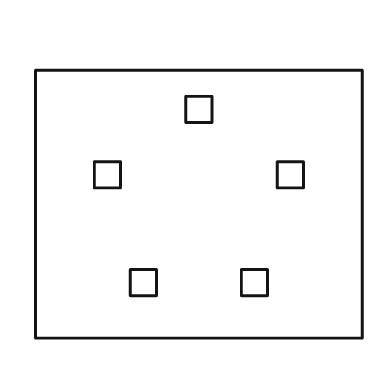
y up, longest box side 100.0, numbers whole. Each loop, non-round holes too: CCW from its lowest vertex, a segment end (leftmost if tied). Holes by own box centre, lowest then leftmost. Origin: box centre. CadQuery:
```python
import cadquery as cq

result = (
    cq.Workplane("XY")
    .moveTo(-50.0, -41.0)
    .lineTo(50.0, -41.0)
    .lineTo(50.0, 41.0)
    .lineTo(-50.0, 41.0)
    .close()
    .moveTo(-21.0, -28.0)
    .lineTo(-13.0, -28.0)
    .lineTo(-13.0, -20.0)
    .lineTo(-21.0, -20.0)
    .close()
    .moveTo(13.0, -28.0)
    .lineTo(21.0, -28.0)
    .lineTo(21.0, -20.0)
    .lineTo(13.0, -20.0)
    .close()
    .moveTo(-32.0, 5.0)
    .lineTo(-24.0, 5.0)
    .lineTo(-24.0, 13.0)
    .lineTo(-32.0, 13.0)
    .close()
    .moveTo(24.0, 5.0)
    .lineTo(32.0, 5.0)
    .lineTo(32.0, 13.0)
    .lineTo(24.0, 13.0)
    .close()
    .moveTo(-4.0, 25.0)
    .lineTo(4.0, 25.0)
    .lineTo(4.0, 33.0)
    .lineTo(-4.0, 33.0)
    .close()
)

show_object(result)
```